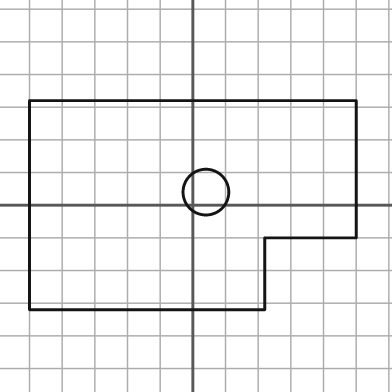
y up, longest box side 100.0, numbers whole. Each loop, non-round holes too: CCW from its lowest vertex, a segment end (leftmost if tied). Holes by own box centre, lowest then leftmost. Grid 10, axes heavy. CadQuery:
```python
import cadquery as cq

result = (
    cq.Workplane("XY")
    .moveTo(-50.0, -32.0)
    .lineTo(22.0, -32.0)
    .lineTo(22.0, -10.0)
    .lineTo(50.0, -10.0)
    .lineTo(50.0, 32.0)
    .lineTo(-50.0, 32.0)
    .close()
    .moveTo(4.0, 4.0)
    .circle(7.0)
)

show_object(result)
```